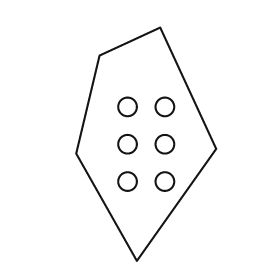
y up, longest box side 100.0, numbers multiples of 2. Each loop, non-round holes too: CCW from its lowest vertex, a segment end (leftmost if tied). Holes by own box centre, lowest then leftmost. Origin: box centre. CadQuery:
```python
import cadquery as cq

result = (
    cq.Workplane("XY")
    .moveTo(-4.0, -50.0)
    .lineTo(30.0, -2.0)
    .lineTo(6.0, 50.0)
    .lineTo(-20.0, 38.0)
    .lineTo(-30.0, -4.0)
    .close()
    .moveTo(-8.0, -16.0)
    .circle(4.0)
    .moveTo(8.0, -16.0)
    .circle(4.0)
    .moveTo(-8.0, 0.0)
    .circle(4.0)
    .moveTo(8.0, 0.0)
    .circle(4.0)
    .moveTo(-8.0, 16.0)
    .circle(4.0)
    .moveTo(8.0, 16.0)
    .circle(4.0)
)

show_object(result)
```